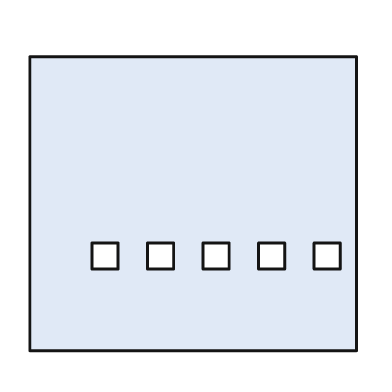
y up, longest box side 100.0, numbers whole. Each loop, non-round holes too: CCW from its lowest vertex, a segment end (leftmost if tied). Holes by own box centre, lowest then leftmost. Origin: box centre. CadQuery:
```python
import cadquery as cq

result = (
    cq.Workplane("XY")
    .moveTo(-50.0, -45.0)
    .lineTo(50.0, -45.0)
    .lineTo(50.0, 45.0)
    .lineTo(-50.0, 45.0)
    .close()
    .moveTo(-31.0, -20.0)
    .lineTo(-23.0, -20.0)
    .lineTo(-23.0, -12.0)
    .lineTo(-31.0, -12.0)
    .close()
    .moveTo(-14.0, -20.0)
    .lineTo(-6.0, -20.0)
    .lineTo(-6.0, -12.0)
    .lineTo(-14.0, -12.0)
    .close()
    .moveTo(3.0, -20.0)
    .lineTo(11.0, -20.0)
    .lineTo(11.0, -12.0)
    .lineTo(3.0, -12.0)
    .close()
    .moveTo(20.0, -20.0)
    .lineTo(28.0, -20.0)
    .lineTo(28.0, -12.0)
    .lineTo(20.0, -12.0)
    .close()
    .moveTo(37.0, -20.0)
    .lineTo(45.0, -20.0)
    .lineTo(45.0, -12.0)
    .lineTo(37.0, -12.0)
    .close()
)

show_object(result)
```